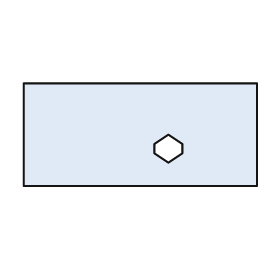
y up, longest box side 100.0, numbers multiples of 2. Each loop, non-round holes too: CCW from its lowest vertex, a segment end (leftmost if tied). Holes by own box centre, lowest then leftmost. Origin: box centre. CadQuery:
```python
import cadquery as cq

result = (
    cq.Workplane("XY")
    .moveTo(-50.0, -22.0)
    .lineTo(50.0, -22.0)
    .lineTo(50.0, 22.0)
    .lineTo(-50.0, 22.0)
    .close()
    .moveTo(12.0, -12.0)
    .lineTo(18.0, -8.0)
    .lineTo(18.0, -4.0)
    .lineTo(12.0, 0.0)
    .lineTo(6.0, -4.0)
    .lineTo(6.0, -8.0)
    .close()
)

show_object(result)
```